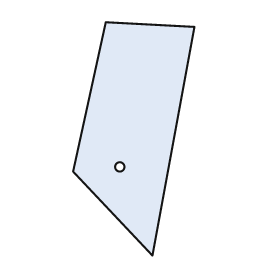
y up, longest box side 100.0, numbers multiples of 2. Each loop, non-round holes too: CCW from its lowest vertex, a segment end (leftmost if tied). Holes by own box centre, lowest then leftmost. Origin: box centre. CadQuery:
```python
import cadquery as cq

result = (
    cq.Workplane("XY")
    .moveTo(8.0, -50.0)
    .lineTo(26.0, 48.0)
    .lineTo(-12.0, 50.0)
    .lineTo(-26.0, -14.0)
    .close()
    .moveTo(-6.0, -12.0)
    .circle(2.0)
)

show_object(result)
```